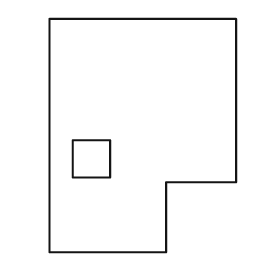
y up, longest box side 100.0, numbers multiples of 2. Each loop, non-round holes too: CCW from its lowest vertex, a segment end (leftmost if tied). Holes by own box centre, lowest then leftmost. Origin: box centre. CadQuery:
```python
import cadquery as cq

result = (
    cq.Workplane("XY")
    .moveTo(-40.0, -50.0)
    .lineTo(10.0, -50.0)
    .lineTo(10.0, -20.0)
    .lineTo(40.0, -20.0)
    .lineTo(40.0, 50.0)
    .lineTo(-40.0, 50.0)
    .close()
    .moveTo(-30.0, -18.0)
    .lineTo(-14.0, -18.0)
    .lineTo(-14.0, -2.0)
    .lineTo(-30.0, -2.0)
    .close()
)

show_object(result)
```